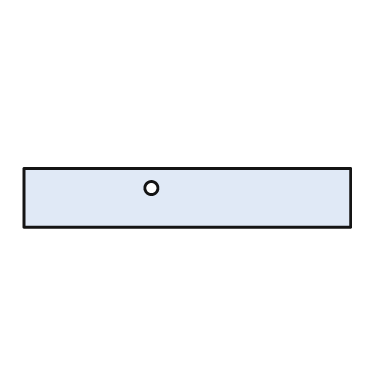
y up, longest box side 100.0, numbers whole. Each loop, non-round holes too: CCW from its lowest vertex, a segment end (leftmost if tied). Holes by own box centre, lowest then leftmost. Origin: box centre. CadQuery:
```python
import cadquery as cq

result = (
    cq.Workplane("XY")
    .moveTo(-50.0, -9.0)
    .lineTo(50.0, -9.0)
    .lineTo(50.0, 9.0)
    .lineTo(-50.0, 9.0)
    .close()
    .moveTo(-11.0, 3.0)
    .circle(2.0)
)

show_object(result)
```